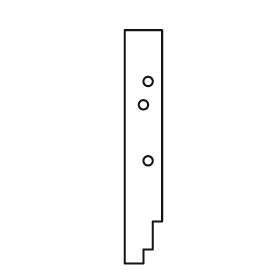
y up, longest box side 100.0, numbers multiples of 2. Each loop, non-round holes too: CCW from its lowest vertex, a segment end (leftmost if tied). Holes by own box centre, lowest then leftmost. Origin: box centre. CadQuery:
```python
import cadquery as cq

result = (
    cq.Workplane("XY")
    .moveTo(-8.0, -50.0)
    .lineTo(0.0, -50.0)
    .lineTo(0.0, -44.0)
    .lineTo(4.0, -44.0)
    .lineTo(4.0, -32.0)
    .lineTo(8.0, -32.0)
    .lineTo(8.0, 50.0)
    .lineTo(-8.0, 50.0)
    .close()
    .moveTo(2.0, -6.0)
    .circle(2.0)
    .moveTo(0.0, 18.0)
    .circle(2.0)
    .moveTo(2.0, 28.0)
    .circle(2.0)
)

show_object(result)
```